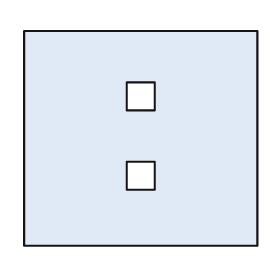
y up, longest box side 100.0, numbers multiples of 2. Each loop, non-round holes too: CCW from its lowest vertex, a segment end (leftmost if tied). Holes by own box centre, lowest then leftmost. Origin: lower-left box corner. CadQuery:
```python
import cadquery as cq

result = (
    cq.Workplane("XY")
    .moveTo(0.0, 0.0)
    .lineTo(100.0, 0.0)
    .lineTo(100.0, 92.0)
    .lineTo(0.0, 92.0)
    .close()
    .moveTo(44.0, 24.0)
    .lineTo(56.0, 24.0)
    .lineTo(56.0, 36.0)
    .lineTo(44.0, 36.0)
    .close()
    .moveTo(44.0, 58.0)
    .lineTo(56.0, 58.0)
    .lineTo(56.0, 70.0)
    .lineTo(44.0, 70.0)
    .close()
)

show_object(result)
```